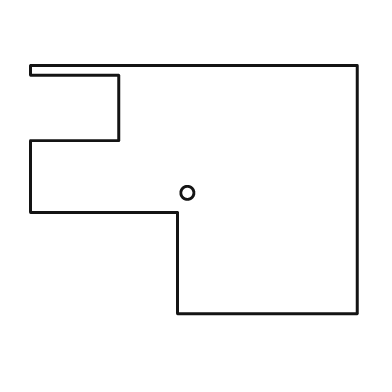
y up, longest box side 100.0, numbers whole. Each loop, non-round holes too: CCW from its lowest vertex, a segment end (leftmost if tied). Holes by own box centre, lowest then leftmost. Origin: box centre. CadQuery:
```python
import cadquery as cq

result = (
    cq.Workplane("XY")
    .moveTo(-5.0, -38.0)
    .lineTo(50.0, -38.0)
    .lineTo(50.0, 38.0)
    .lineTo(-50.0, 38.0)
    .lineTo(-50.0, 35.0)
    .lineTo(-23.0, 35.0)
    .lineTo(-23.0, 15.0)
    .lineTo(-50.0, 15.0)
    .lineTo(-50.0, -7.0)
    .lineTo(-5.0, -7.0)
    .close()
    .moveTo(-2.0, -1.0)
    .circle(2.0)
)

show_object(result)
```